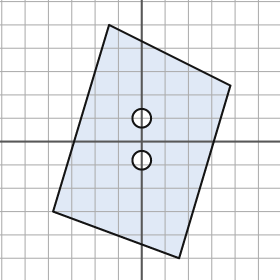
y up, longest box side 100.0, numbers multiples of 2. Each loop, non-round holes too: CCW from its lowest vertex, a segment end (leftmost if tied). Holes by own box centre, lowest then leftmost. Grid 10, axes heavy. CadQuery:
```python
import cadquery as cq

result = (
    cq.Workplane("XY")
    .moveTo(16.0, -50.0)
    .lineTo(38.0, 24.0)
    .lineTo(-14.0, 50.0)
    .lineTo(-38.0, -30.0)
    .close()
    .moveTo(0.0, -8.0)
    .circle(4.0)
    .moveTo(0.0, 10.0)
    .circle(4.0)
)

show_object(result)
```